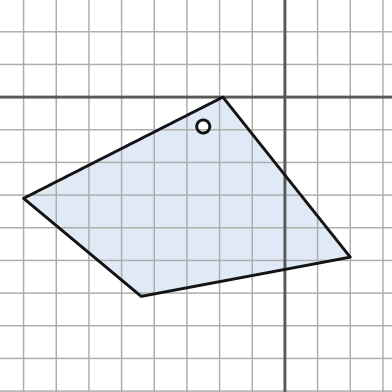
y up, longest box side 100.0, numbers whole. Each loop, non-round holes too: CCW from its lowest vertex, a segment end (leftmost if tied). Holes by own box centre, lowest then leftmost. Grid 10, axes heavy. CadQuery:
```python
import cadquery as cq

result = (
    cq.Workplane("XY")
    .moveTo(-44.0, -61.0)
    .lineTo(20.0, -49.0)
    .lineTo(-19.0, 0.0)
    .lineTo(-80.0, -31.0)
    .close()
    .moveTo(-25.0, -9.0)
    .circle(2.0)
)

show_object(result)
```